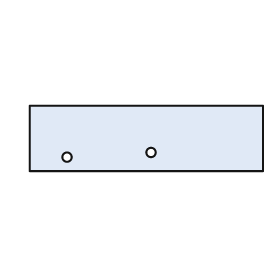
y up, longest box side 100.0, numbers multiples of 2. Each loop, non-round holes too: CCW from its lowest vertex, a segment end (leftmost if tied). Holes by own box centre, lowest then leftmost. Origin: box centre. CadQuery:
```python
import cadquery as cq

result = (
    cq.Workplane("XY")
    .moveTo(-50.0, -14.0)
    .lineTo(50.0, -14.0)
    .lineTo(50.0, 14.0)
    .lineTo(-50.0, 14.0)
    .close()
    .moveTo(-34.0, -8.0)
    .circle(2.0)
    .moveTo(2.0, -6.0)
    .circle(2.0)
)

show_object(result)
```